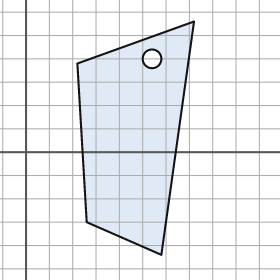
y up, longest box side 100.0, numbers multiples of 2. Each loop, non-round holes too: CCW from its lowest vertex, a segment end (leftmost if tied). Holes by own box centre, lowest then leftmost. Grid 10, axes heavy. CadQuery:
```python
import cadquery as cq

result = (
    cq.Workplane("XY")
    .moveTo(58.0, -44.0)
    .lineTo(72.0, 56.0)
    .lineTo(22.0, 38.0)
    .lineTo(26.0, -30.0)
    .close()
    .moveTo(54.0, 40.0)
    .circle(4.0)
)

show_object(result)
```